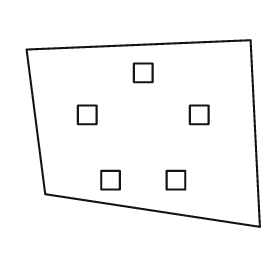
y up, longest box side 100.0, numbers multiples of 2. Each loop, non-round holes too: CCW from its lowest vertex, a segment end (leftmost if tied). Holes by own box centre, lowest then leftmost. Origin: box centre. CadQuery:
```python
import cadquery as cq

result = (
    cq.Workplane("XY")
    .moveTo(50.0, -40.0)
    .lineTo(46.0, 40.0)
    .lineTo(-50.0, 36.0)
    .lineTo(-42.0, -26.0)
    .close()
    .moveTo(-18.0, -24.0)
    .lineTo(-10.0, -24.0)
    .lineTo(-10.0, -16.0)
    .lineTo(-18.0, -16.0)
    .close()
    .moveTo(10.0, -24.0)
    .lineTo(18.0, -24.0)
    .lineTo(18.0, -16.0)
    .lineTo(10.0, -16.0)
    .close()
    .moveTo(-28.0, 4.0)
    .lineTo(-20.0, 4.0)
    .lineTo(-20.0, 12.0)
    .lineTo(-28.0, 12.0)
    .close()
    .moveTo(20.0, 4.0)
    .lineTo(28.0, 4.0)
    .lineTo(28.0, 12.0)
    .lineTo(20.0, 12.0)
    .close()
    .moveTo(-4.0, 22.0)
    .lineTo(4.0, 22.0)
    .lineTo(4.0, 30.0)
    .lineTo(-4.0, 30.0)
    .close()
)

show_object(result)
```